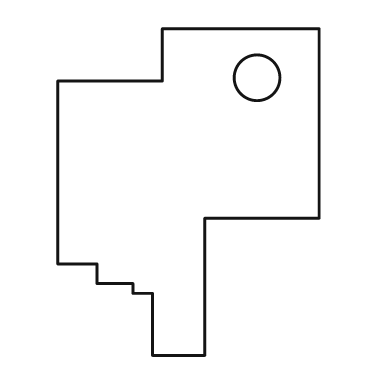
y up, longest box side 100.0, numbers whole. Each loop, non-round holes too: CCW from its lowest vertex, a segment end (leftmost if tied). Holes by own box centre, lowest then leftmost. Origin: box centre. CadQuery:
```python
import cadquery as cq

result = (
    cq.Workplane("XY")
    .moveTo(-11.0, -50.0)
    .lineTo(5.0, -50.0)
    .lineTo(5.0, -8.0)
    .lineTo(40.0, -8.0)
    .lineTo(40.0, 50.0)
    .lineTo(-8.0, 50.0)
    .lineTo(-8.0, 34.0)
    .lineTo(-40.0, 34.0)
    .lineTo(-40.0, -22.0)
    .lineTo(-28.0, -22.0)
    .lineTo(-28.0, -28.0)
    .lineTo(-17.0, -28.0)
    .lineTo(-17.0, -31.0)
    .lineTo(-11.0, -31.0)
    .close()
    .moveTo(21.0, 35.0)
    .circle(7.0)
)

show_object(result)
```